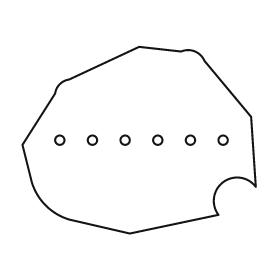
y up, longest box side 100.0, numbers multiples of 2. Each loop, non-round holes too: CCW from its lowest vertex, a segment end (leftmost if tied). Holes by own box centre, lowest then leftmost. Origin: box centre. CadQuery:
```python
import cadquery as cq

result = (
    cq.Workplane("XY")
    .moveTo(-4.0, -40.0)
    .lineTo(34.0, -32.0)
    .threePointArc((36.0, -18.0), (50.0, -20.0))
    .lineTo(48.0, 10.0)
    .lineTo(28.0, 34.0)
    .threePointArc((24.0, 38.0), (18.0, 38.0))
    .lineTo(0.0, 40.0)
    .lineTo(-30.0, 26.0)
    .threePointArc((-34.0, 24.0), (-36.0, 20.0))
    .lineTo(-50.0, -2.0)
    .lineTo(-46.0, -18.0)
    .threePointArc((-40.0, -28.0), (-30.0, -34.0))
    .close()
    .moveTo(-34.0, 0.0)
    .circle(2.0)
    .moveTo(-20.0, 0.0)
    .circle(2.0)
    .moveTo(-6.0, 0.0)
    .circle(2.0)
    .moveTo(8.0, 0.0)
    .circle(2.0)
    .moveTo(22.0, 0.0)
    .circle(2.0)
    .moveTo(36.0, 0.0)
    .circle(2.0)
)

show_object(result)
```